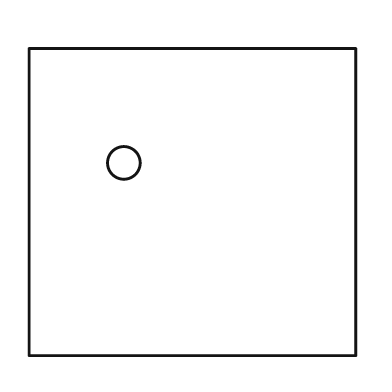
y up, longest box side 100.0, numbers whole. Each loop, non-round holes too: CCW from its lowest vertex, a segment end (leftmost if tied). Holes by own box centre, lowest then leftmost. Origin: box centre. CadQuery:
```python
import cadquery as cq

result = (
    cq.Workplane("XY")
    .moveTo(-50.0, -47.0)
    .lineTo(50.0, -47.0)
    .lineTo(50.0, 47.0)
    .lineTo(-50.0, 47.0)
    .close()
    .moveTo(-21.0, 12.0)
    .circle(5.0)
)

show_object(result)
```